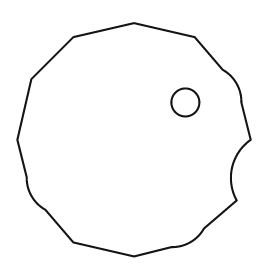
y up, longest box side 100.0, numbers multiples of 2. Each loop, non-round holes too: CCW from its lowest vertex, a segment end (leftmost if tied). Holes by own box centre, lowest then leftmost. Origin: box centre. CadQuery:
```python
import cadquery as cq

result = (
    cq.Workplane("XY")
    .moveTo(0.0, -50.0)
    .lineTo(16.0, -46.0)
    .threePointArc((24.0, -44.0), (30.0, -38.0))
    .lineTo(44.0, -26.0)
    .threePointArc((42.0, -12.0), (50.0, 0.0))
    .lineTo(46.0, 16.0)
    .threePointArc((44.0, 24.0), (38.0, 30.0))
    .lineTo(26.0, 44.0)
    .lineTo(0.0, 50.0)
    .lineTo(-26.0, 44.0)
    .lineTo(-44.0, 26.0)
    .lineTo(-50.0, 0.0)
    .lineTo(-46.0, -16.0)
    .threePointArc((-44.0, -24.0), (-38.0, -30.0))
    .lineTo(-26.0, -44.0)
    .close()
    .moveTo(22.0, 16.0)
    .circle(6.0)
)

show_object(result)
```